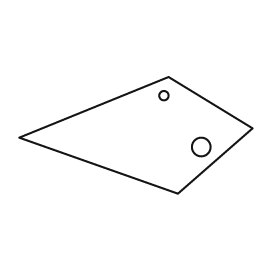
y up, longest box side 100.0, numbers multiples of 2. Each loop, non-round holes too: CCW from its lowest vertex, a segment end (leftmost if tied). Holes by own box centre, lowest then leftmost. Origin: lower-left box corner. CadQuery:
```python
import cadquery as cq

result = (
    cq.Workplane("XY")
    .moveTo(68.0, 0.0)
    .lineTo(100.0, 28.0)
    .lineTo(64.0, 50.0)
    .lineTo(0.0, 24.0)
    .close()
    .moveTo(78.0, 20.0)
    .circle(4.0)
    .moveTo(62.0, 42.0)
    .circle(2.0)
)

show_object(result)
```